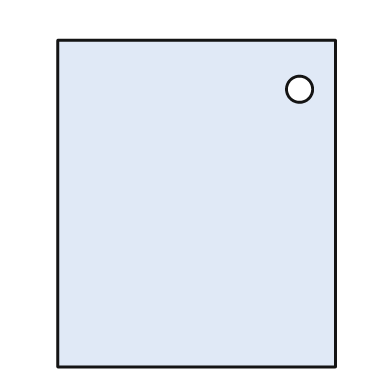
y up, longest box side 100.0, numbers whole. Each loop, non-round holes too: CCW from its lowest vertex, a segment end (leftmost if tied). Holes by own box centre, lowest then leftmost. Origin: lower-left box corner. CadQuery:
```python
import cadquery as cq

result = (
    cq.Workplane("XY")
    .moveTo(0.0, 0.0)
    .lineTo(85.0, 0.0)
    .lineTo(85.0, 100.0)
    .lineTo(0.0, 100.0)
    .close()
    .moveTo(74.0, 85.0)
    .circle(4.0)
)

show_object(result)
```